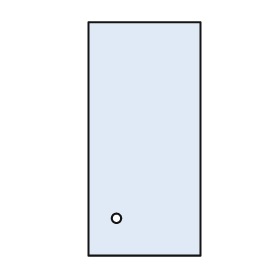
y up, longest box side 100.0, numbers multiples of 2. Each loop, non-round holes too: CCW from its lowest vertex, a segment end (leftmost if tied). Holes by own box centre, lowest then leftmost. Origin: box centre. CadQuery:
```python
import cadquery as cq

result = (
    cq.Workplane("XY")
    .moveTo(-24.0, -50.0)
    .lineTo(24.0, -50.0)
    .lineTo(24.0, 50.0)
    .lineTo(-24.0, 50.0)
    .close()
    .moveTo(-12.0, -34.0)
    .circle(2.0)
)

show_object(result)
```